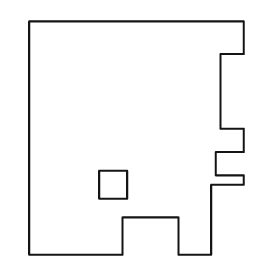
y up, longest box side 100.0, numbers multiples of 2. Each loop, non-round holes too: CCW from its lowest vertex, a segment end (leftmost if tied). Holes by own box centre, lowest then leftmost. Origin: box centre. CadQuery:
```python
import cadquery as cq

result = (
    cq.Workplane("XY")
    .moveTo(-46.0, -50.0)
    .lineTo(-6.0, -50.0)
    .lineTo(-6.0, -34.0)
    .lineTo(18.0, -34.0)
    .lineTo(18.0, -50.0)
    .lineTo(32.0, -50.0)
    .lineTo(32.0, -20.0)
    .lineTo(46.0, -20.0)
    .lineTo(46.0, -16.0)
    .lineTo(34.0, -16.0)
    .lineTo(34.0, -6.0)
    .lineTo(46.0, -6.0)
    .lineTo(46.0, 4.0)
    .lineTo(36.0, 4.0)
    .lineTo(36.0, 36.0)
    .lineTo(46.0, 36.0)
    .lineTo(46.0, 50.0)
    .lineTo(-46.0, 50.0)
    .close()
    .moveTo(-16.0, -26.0)
    .lineTo(-4.0, -26.0)
    .lineTo(-4.0, -14.0)
    .lineTo(-16.0, -14.0)
    .close()
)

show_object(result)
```